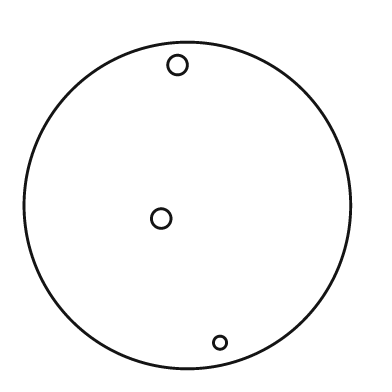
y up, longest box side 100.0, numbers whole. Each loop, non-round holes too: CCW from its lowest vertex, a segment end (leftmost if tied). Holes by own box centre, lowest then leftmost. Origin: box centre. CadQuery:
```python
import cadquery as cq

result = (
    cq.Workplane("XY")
    .moveTo(0.0, 0.0)
    .circle(50.0)
    .moveTo(10.0, -42.0)
    .circle(2.0)
    .moveTo(-8.0, -4.0)
    .circle(3.0)
    .moveTo(-3.0, 43.0)
    .circle(3.0)
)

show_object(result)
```